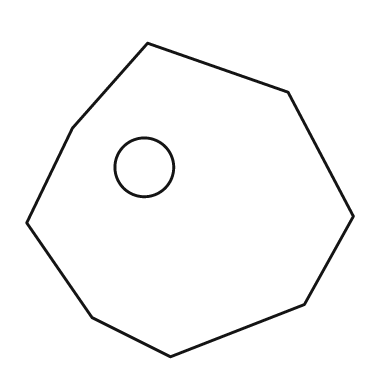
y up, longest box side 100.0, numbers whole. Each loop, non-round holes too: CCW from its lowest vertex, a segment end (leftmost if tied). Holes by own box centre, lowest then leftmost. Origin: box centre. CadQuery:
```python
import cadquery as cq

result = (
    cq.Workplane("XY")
    .moveTo(-6.0, -48.0)
    .lineTo(35.0, -32.0)
    .lineTo(50.0, -5.0)
    .lineTo(30.0, 33.0)
    .lineTo(-13.0, 48.0)
    .lineTo(-36.0, 22.0)
    .lineTo(-50.0, -7.0)
    .lineTo(-30.0, -36.0)
    .close()
    .moveTo(-14.0, 10.0)
    .circle(9.0)
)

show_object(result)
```